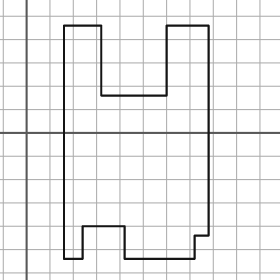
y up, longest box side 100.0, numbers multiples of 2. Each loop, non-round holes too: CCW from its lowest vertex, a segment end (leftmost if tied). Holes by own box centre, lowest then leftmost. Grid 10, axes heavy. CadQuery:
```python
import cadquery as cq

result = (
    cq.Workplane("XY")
    .moveTo(16.0, -54.0)
    .lineTo(24.0, -54.0)
    .lineTo(24.0, -40.0)
    .lineTo(42.0, -40.0)
    .lineTo(42.0, -54.0)
    .lineTo(72.0, -54.0)
    .lineTo(72.0, -44.0)
    .lineTo(78.0, -44.0)
    .lineTo(78.0, 46.0)
    .lineTo(60.0, 46.0)
    .lineTo(60.0, 16.0)
    .lineTo(32.0, 16.0)
    .lineTo(32.0, 46.0)
    .lineTo(16.0, 46.0)
    .close()
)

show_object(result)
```